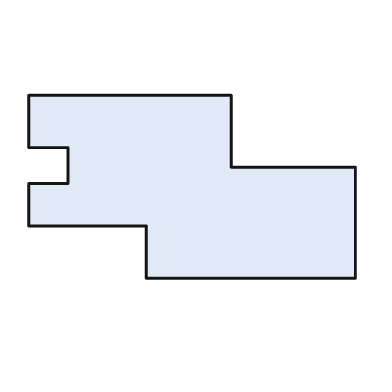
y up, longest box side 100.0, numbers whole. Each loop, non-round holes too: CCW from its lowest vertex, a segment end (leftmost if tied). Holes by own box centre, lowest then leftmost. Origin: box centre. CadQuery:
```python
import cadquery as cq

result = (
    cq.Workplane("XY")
    .moveTo(-14.0, -28.0)
    .lineTo(50.0, -28.0)
    .lineTo(50.0, 6.0)
    .lineTo(12.0, 6.0)
    .lineTo(12.0, 28.0)
    .lineTo(-50.0, 28.0)
    .lineTo(-50.0, 12.0)
    .lineTo(-38.0, 12.0)
    .lineTo(-38.0, 1.0)
    .lineTo(-50.0, 1.0)
    .lineTo(-50.0, -12.0)
    .lineTo(-14.0, -12.0)
    .close()
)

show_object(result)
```